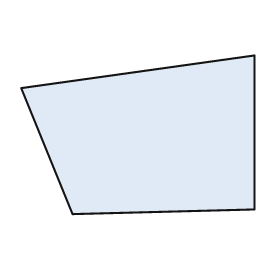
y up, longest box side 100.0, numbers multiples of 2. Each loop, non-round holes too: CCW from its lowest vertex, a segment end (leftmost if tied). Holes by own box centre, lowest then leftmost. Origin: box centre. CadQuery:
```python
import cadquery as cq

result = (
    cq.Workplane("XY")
    .moveTo(-28.0, -34.0)
    .lineTo(50.0, -32.0)
    .lineTo(50.0, 34.0)
    .lineTo(-50.0, 20.0)
    .close()
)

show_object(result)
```